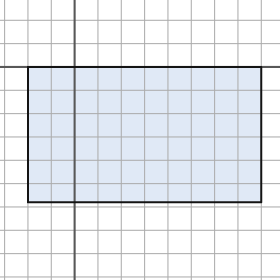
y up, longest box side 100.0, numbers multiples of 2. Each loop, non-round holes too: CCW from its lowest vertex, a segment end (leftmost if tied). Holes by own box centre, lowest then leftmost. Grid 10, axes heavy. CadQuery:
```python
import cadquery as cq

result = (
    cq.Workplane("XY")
    .moveTo(-20.0, -58.0)
    .lineTo(80.0, -58.0)
    .lineTo(80.0, 0.0)
    .lineTo(-20.0, 0.0)
    .close()
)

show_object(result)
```